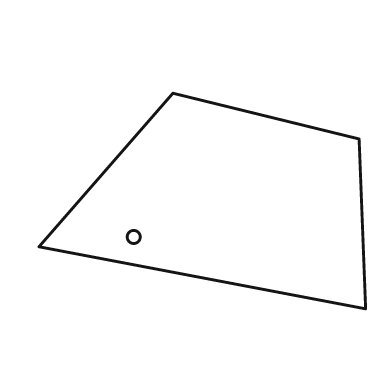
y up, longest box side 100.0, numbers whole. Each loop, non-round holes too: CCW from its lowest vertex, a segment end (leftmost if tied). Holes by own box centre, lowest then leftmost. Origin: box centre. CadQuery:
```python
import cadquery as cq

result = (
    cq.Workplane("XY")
    .moveTo(50.0, -33.0)
    .lineTo(48.0, 19.0)
    .lineTo(-9.0, 33.0)
    .lineTo(-50.0, -14.0)
    .close()
    .moveTo(-21.0, -11.0)
    .circle(2.0)
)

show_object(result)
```